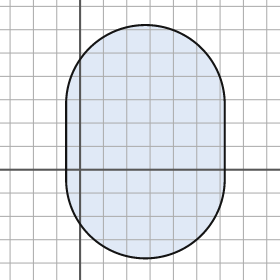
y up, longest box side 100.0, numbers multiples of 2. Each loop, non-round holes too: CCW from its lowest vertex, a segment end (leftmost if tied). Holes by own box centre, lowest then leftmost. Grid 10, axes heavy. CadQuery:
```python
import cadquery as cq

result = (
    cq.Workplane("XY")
    .moveTo(-6.0, -4.0)
    .threePointArc((28.0, -38.0), (62.0, -4.0))
    .lineTo(62.0, 28.0)
    .threePointArc((28.0, 62.0), (-6.0, 28.0))
    .close()
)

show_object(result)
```